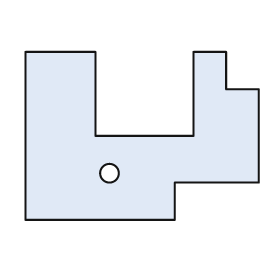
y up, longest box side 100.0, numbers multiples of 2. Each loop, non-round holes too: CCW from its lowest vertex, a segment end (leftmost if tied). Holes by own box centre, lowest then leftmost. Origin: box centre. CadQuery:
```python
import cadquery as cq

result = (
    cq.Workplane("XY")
    .moveTo(-50.0, -36.0)
    .lineTo(14.0, -36.0)
    .lineTo(14.0, -20.0)
    .lineTo(50.0, -20.0)
    .lineTo(50.0, 20.0)
    .lineTo(36.0, 20.0)
    .lineTo(36.0, 36.0)
    .lineTo(22.0, 36.0)
    .lineTo(22.0, 0.0)
    .lineTo(-20.0, 0.0)
    .lineTo(-20.0, 36.0)
    .lineTo(-50.0, 36.0)
    .close()
    .moveTo(-14.0, -16.0)
    .circle(4.0)
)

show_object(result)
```